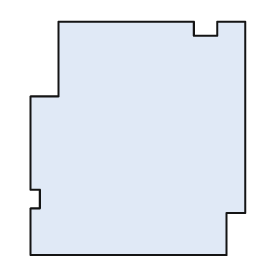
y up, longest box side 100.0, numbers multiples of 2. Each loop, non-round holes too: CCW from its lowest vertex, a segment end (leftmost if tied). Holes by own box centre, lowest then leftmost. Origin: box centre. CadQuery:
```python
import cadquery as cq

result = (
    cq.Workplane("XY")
    .moveTo(-46.0, -50.0)
    .lineTo(38.0, -50.0)
    .lineTo(38.0, -32.0)
    .lineTo(46.0, -32.0)
    .lineTo(46.0, 50.0)
    .lineTo(34.0, 50.0)
    .lineTo(34.0, 44.0)
    .lineTo(24.0, 44.0)
    .lineTo(24.0, 50.0)
    .lineTo(-34.0, 50.0)
    .lineTo(-34.0, 18.0)
    .lineTo(-46.0, 18.0)
    .lineTo(-46.0, -22.0)
    .lineTo(-42.0, -22.0)
    .lineTo(-42.0, -30.0)
    .lineTo(-46.0, -30.0)
    .close()
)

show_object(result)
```